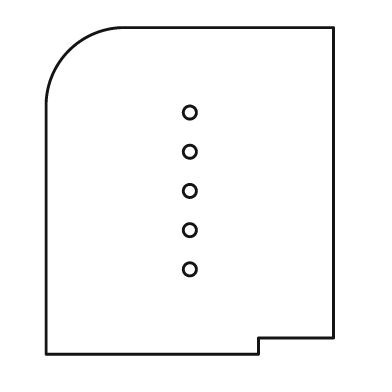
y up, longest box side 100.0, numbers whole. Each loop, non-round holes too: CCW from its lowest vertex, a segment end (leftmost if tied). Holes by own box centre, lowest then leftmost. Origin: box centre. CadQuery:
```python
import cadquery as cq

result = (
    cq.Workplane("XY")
    .moveTo(-44.0, -50.0)
    .lineTo(21.0, -50.0)
    .lineTo(21.0, -45.0)
    .lineTo(44.0, -45.0)
    .lineTo(44.0, 50.0)
    .lineTo(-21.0, 50.0)
    .threePointArc((-37.0, 43.0), (-44.0, 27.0))
    .close()
    .moveTo(0.0, -24.0)
    .circle(2.0)
    .moveTo(0.0, -12.0)
    .circle(2.0)
    .moveTo(0.0, 0.0)
    .circle(2.0)
    .moveTo(0.0, 12.0)
    .circle(2.0)
    .moveTo(0.0, 24.0)
    .circle(2.0)
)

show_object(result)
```